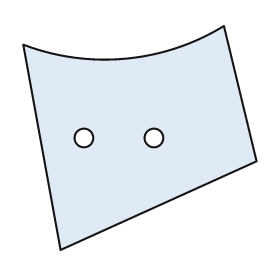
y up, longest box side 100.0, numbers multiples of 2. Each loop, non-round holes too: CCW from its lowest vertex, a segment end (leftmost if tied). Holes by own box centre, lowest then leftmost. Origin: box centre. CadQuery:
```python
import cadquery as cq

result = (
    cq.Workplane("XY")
    .moveTo(-34.0, -48.0)
    .lineTo(50.0, -10.0)
    .lineTo(36.0, 48.0)
    .threePointArc((-6.0, 34.0), (-50.0, 40.0))
    .close()
    .moveTo(-24.0, 0.0)
    .circle(4.0)
    .moveTo(6.0, 0.0)
    .circle(4.0)
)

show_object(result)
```